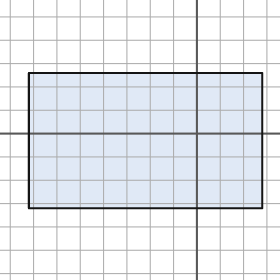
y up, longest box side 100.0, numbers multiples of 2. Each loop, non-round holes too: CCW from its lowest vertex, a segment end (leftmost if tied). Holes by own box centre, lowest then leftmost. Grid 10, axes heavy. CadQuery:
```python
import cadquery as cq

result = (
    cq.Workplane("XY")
    .moveTo(-72.0, -32.0)
    .lineTo(28.0, -32.0)
    .lineTo(28.0, 26.0)
    .lineTo(-72.0, 26.0)
    .close()
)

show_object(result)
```